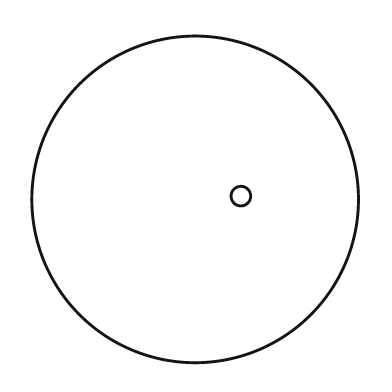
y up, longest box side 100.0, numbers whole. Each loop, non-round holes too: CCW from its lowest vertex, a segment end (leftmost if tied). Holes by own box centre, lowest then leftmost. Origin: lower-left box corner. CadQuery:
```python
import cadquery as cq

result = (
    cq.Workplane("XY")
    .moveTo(50.0, 50.0)
    .circle(50.0)
    .moveTo(64.0, 51.0)
    .circle(3.0)
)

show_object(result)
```